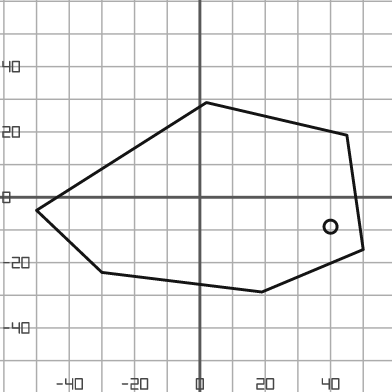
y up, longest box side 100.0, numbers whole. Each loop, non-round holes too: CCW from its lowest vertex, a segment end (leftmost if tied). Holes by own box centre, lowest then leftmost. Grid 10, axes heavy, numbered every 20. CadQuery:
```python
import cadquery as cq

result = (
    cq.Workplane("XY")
    .moveTo(19.0, -29.0)
    .lineTo(50.0, -16.0)
    .lineTo(45.0, 19.0)
    .lineTo(2.0, 29.0)
    .lineTo(-50.0, -4.0)
    .lineTo(-30.0, -23.0)
    .close()
    .moveTo(40.0, -9.0)
    .circle(2.0)
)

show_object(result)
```